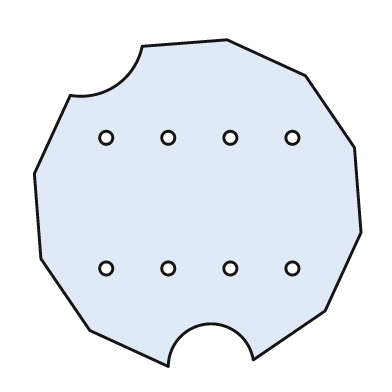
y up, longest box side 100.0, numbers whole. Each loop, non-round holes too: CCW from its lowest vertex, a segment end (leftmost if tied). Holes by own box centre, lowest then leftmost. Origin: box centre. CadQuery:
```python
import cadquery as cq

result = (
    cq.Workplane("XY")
    .moveTo(-9.0, -50.0)
    .threePointArc((3.0, -37.0), (17.0, -48.0))
    .lineTo(39.0, -33.0)
    .lineTo(50.0, -9.0)
    .lineTo(48.0, 17.0)
    .lineTo(33.0, 39.0)
    .lineTo(9.0, 50.0)
    .lineTo(-17.0, 48.0)
    .threePointArc((-25.0, 36.0), (-39.0, 33.0))
    .lineTo(-50.0, 9.0)
    .lineTo(-48.0, -17.0)
    .lineTo(-33.0, -39.0)
    .close()
    .moveTo(-28.0, -20.0)
    .circle(2.0)
    .moveTo(-9.0, -20.0)
    .circle(2.0)
    .moveTo(10.0, -20.0)
    .circle(2.0)
    .moveTo(29.0, -20.0)
    .circle(2.0)
    .moveTo(-28.0, 20.0)
    .circle(2.0)
    .moveTo(-9.0, 20.0)
    .circle(2.0)
    .moveTo(10.0, 20.0)
    .circle(2.0)
    .moveTo(29.0, 20.0)
    .circle(2.0)
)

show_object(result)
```